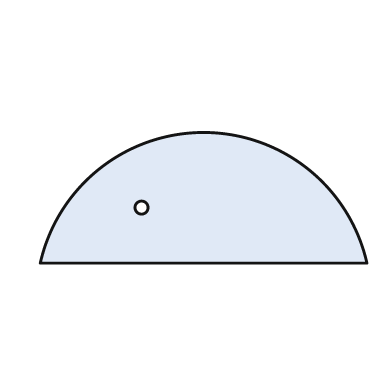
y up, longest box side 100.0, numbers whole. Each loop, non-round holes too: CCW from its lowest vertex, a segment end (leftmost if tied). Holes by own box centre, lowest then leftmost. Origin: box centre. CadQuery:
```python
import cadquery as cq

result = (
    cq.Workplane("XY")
    .moveTo(-50.0, -20.0)
    .lineTo(50.0, -20.0)
    .threePointArc((0.0, 20.0), (-50.0, -20.0))
    .close()
    .moveTo(-19.0, -3.0)
    .circle(2.0)
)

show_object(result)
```